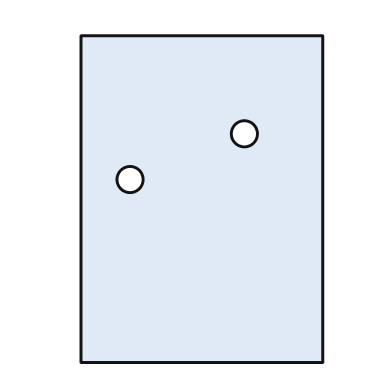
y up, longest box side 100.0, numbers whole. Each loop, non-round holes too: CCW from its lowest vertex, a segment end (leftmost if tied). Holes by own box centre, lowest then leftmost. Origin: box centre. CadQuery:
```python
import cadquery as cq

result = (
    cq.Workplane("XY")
    .moveTo(-37.0, -50.0)
    .lineTo(37.0, -50.0)
    .lineTo(37.0, 50.0)
    .lineTo(-37.0, 50.0)
    .close()
    .moveTo(-22.0, 6.0)
    .circle(4.0)
    .moveTo(13.0, 20.0)
    .circle(4.0)
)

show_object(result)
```